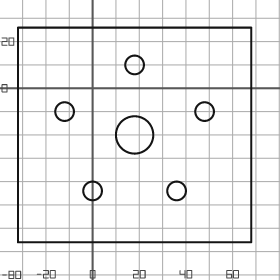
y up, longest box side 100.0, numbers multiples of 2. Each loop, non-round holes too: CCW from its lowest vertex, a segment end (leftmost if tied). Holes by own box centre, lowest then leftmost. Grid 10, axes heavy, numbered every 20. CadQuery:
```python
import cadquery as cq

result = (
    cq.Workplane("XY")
    .moveTo(-32.0, -66.0)
    .lineTo(68.0, -66.0)
    .lineTo(68.0, 26.0)
    .lineTo(-32.0, 26.0)
    .close()
    .moveTo(0.0, -44.0)
    .circle(4.0)
    .moveTo(36.0, -44.0)
    .circle(4.0)
    .moveTo(18.0, -20.0)
    .circle(8.0)
    .moveTo(-12.0, -10.0)
    .circle(4.0)
    .moveTo(48.0, -10.0)
    .circle(4.0)
    .moveTo(18.0, 10.0)
    .circle(4.0)
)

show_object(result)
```